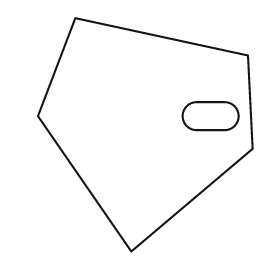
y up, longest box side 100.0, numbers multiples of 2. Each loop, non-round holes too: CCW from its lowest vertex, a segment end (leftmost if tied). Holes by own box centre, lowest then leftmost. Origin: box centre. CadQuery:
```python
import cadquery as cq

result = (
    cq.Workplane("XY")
    .moveTo(-6.0, -50.0)
    .lineTo(46.0, -6.0)
    .lineTo(44.0, 34.0)
    .lineTo(-30.0, 50.0)
    .lineTo(-46.0, 8.0)
    .close()
    .moveTo(22.0, 2.0)
    .lineTo(34.0, 2.0)
    .threePointArc((40.0, 8.0), (34.0, 14.0))
    .lineTo(22.0, 14.0)
    .threePointArc((16.0, 8.0), (22.0, 2.0))
    .close()
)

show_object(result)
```